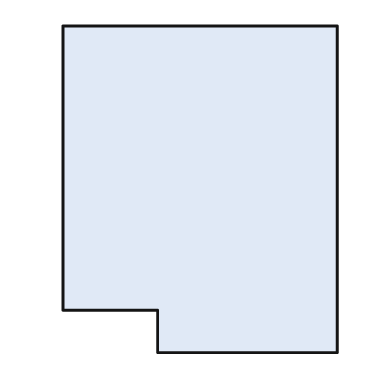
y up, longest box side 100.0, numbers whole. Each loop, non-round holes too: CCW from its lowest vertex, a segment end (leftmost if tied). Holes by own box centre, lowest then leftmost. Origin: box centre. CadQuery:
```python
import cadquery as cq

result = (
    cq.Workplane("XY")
    .moveTo(-13.0, -50.0)
    .lineTo(42.0, -50.0)
    .lineTo(42.0, 50.0)
    .lineTo(-42.0, 50.0)
    .lineTo(-42.0, -37.0)
    .lineTo(-13.0, -37.0)
    .close()
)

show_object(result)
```